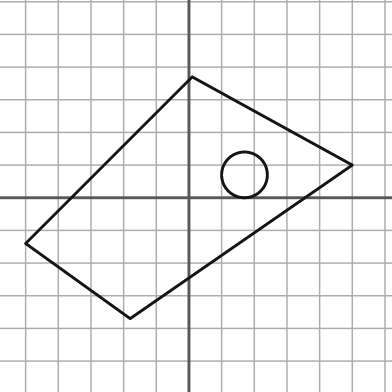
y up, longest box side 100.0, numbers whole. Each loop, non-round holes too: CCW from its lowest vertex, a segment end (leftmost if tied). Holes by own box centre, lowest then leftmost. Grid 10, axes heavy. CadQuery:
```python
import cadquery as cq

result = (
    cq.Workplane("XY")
    .moveTo(-18.0, -37.0)
    .lineTo(50.0, 10.0)
    .lineTo(1.0, 37.0)
    .lineTo(-50.0, -14.0)
    .close()
    .moveTo(17.0, 7.0)
    .circle(7.0)
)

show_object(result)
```